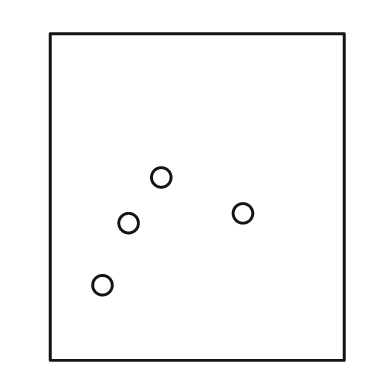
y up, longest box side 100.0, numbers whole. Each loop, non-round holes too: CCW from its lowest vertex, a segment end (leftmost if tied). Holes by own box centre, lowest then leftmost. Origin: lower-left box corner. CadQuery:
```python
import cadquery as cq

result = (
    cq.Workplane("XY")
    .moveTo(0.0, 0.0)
    .lineTo(90.0, 0.0)
    .lineTo(90.0, 100.0)
    .lineTo(0.0, 100.0)
    .close()
    .moveTo(16.0, 23.0)
    .circle(3.0)
    .moveTo(24.0, 42.0)
    .circle(3.0)
    .moveTo(59.0, 45.0)
    .circle(3.0)
    .moveTo(34.0, 56.0)
    .circle(3.0)
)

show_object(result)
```